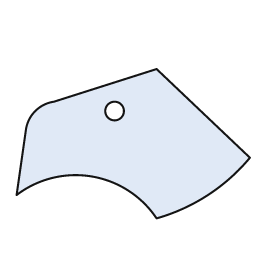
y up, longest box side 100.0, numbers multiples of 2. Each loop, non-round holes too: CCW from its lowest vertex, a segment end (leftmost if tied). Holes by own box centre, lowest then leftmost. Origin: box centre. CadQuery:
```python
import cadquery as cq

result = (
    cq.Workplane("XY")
    .moveTo(10.0, -32.0)
    .threePointArc((32.0, -22.0), (50.0, -6.0))
    .lineTo(10.0, 32.0)
    .lineTo(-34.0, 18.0)
    .threePointArc((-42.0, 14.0), (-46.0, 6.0))
    .lineTo(-50.0, -22.0)
    .threePointArc((-18.0, -14.0), (10.0, -32.0))
    .close()
    .moveTo(-8.0, 14.0)
    .circle(4.0)
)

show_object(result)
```